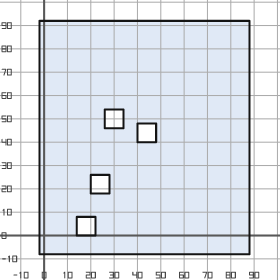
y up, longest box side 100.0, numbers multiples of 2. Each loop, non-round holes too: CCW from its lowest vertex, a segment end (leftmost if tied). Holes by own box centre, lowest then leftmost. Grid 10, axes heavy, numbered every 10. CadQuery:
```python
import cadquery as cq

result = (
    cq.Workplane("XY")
    .moveTo(-2.0, -8.0)
    .lineTo(88.0, -8.0)
    .lineTo(88.0, 92.0)
    .lineTo(-2.0, 92.0)
    .close()
    .moveTo(14.0, 0.0)
    .lineTo(22.0, 0.0)
    .lineTo(22.0, 8.0)
    .lineTo(14.0, 8.0)
    .close()
    .moveTo(20.0, 18.0)
    .lineTo(28.0, 18.0)
    .lineTo(28.0, 26.0)
    .lineTo(20.0, 26.0)
    .close()
    .moveTo(40.0, 40.0)
    .lineTo(48.0, 40.0)
    .lineTo(48.0, 48.0)
    .lineTo(40.0, 48.0)
    .close()
    .moveTo(26.0, 46.0)
    .lineTo(34.0, 46.0)
    .lineTo(34.0, 54.0)
    .lineTo(26.0, 54.0)
    .close()
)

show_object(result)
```